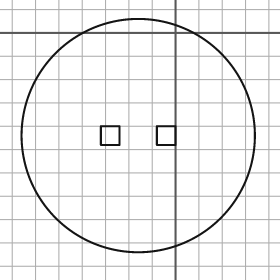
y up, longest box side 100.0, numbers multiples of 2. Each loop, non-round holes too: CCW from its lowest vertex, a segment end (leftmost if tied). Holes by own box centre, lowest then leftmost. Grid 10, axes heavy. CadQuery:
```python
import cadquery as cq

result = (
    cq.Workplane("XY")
    .moveTo(-16.0, -44.0)
    .circle(50.0)
    .moveTo(-32.0, -48.0)
    .lineTo(-24.0, -48.0)
    .lineTo(-24.0, -40.0)
    .lineTo(-32.0, -40.0)
    .close()
    .moveTo(-8.0, -48.0)
    .lineTo(0.0, -48.0)
    .lineTo(0.0, -40.0)
    .lineTo(-8.0, -40.0)
    .close()
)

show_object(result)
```